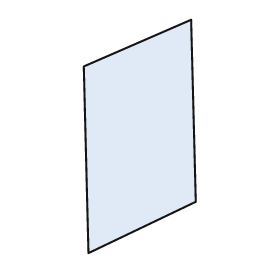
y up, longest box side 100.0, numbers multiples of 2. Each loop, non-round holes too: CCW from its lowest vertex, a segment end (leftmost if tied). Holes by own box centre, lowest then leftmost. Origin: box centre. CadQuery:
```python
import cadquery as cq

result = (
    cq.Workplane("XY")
    .moveTo(-22.0, -50.0)
    .lineTo(24.0, -28.0)
    .lineTo(22.0, 50.0)
    .lineTo(-24.0, 30.0)
    .close()
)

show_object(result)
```